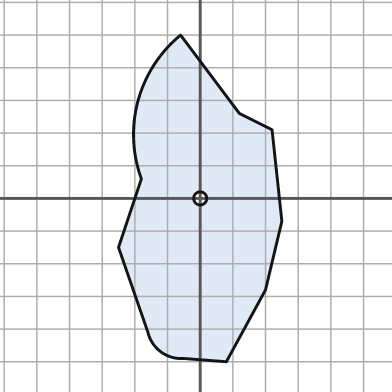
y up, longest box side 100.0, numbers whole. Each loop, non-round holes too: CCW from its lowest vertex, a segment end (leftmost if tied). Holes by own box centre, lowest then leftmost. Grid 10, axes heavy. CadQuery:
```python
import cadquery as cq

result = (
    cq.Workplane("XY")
    .moveTo(8.0, -50.0)
    .lineTo(20.0, -28.0)
    .lineTo(25.0, -7.0)
    .lineTo(22.0, 21.0)
    .lineTo(12.0, 26.0)
    .lineTo(-6.0, 50.0)
    .threePointArc((-19.0, 30.0), (-18.0, 6.0))
    .lineTo(-25.0, -15.0)
    .lineTo(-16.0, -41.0)
    .threePointArc((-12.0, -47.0), (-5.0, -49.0))
    .close()
    .moveTo(0.0, 0.0)
    .circle(2.0)
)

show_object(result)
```